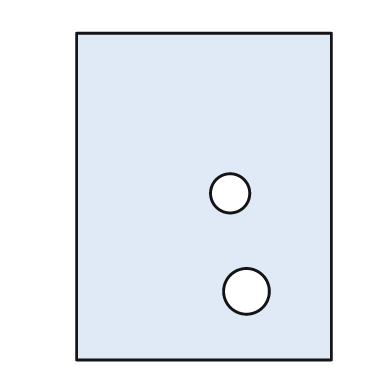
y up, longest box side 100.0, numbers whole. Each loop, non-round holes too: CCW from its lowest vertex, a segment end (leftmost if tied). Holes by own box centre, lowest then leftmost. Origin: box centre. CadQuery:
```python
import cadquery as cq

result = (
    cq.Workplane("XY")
    .moveTo(-39.0, -50.0)
    .lineTo(39.0, -50.0)
    .lineTo(39.0, 50.0)
    .lineTo(-39.0, 50.0)
    .close()
    .moveTo(13.0, -29.0)
    .circle(7.0)
    .moveTo(8.0, 1.0)
    .circle(6.0)
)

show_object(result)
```